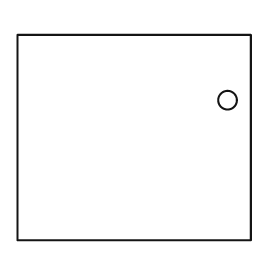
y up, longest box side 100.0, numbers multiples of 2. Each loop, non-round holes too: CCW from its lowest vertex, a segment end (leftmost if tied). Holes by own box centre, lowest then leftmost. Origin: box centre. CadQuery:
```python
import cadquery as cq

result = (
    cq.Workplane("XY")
    .moveTo(-50.0, -44.0)
    .lineTo(50.0, -44.0)
    .lineTo(50.0, 44.0)
    .lineTo(-50.0, 44.0)
    .close()
    .moveTo(40.0, 16.0)
    .circle(4.0)
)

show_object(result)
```